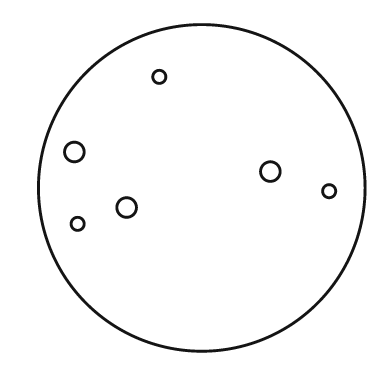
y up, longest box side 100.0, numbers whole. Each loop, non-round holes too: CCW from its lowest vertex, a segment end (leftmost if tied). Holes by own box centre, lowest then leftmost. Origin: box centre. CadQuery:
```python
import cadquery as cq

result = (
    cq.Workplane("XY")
    .moveTo(0.0, 0.0)
    .circle(50.0)
    .moveTo(-38.0, -11.0)
    .circle(2.0)
    .moveTo(-23.0, -6.0)
    .circle(3.0)
    .moveTo(39.0, -1.0)
    .circle(2.0)
    .moveTo(21.0, 5.0)
    .circle(3.0)
    .moveTo(-39.0, 11.0)
    .circle(3.0)
    .moveTo(-13.0, 34.0)
    .circle(2.0)
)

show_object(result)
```